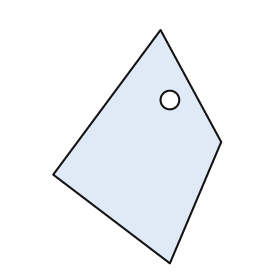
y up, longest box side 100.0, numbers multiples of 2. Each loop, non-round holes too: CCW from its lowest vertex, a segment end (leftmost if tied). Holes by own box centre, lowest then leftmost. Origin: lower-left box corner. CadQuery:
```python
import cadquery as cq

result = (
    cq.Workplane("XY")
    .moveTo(50.0, 0.0)
    .lineTo(72.0, 52.0)
    .lineTo(46.0, 100.0)
    .lineTo(0.0, 38.0)
    .close()
    .moveTo(50.0, 70.0)
    .circle(4.0)
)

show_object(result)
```